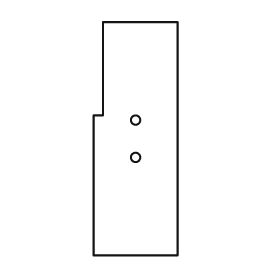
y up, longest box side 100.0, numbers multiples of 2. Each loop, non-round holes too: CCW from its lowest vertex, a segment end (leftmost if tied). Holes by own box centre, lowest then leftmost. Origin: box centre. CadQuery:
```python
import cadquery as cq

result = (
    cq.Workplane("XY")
    .moveTo(-18.0, -50.0)
    .lineTo(18.0, -50.0)
    .lineTo(18.0, 50.0)
    .lineTo(-14.0, 50.0)
    .lineTo(-14.0, 10.0)
    .lineTo(-18.0, 10.0)
    .close()
    .moveTo(0.0, -8.0)
    .circle(2.0)
    .moveTo(0.0, 8.0)
    .circle(2.0)
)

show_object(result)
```